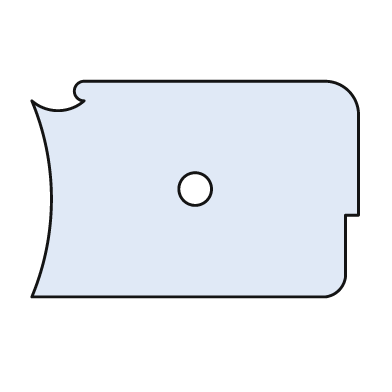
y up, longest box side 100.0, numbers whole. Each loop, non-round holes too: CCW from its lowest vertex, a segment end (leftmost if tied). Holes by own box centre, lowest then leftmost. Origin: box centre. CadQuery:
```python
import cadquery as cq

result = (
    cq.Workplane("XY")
    .moveTo(-50.0, -33.0)
    .lineTo(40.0, -33.0)
    .threePointArc((44.0, -31.0), (46.0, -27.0))
    .lineTo(46.0, -8.0)
    .lineTo(50.0, -8.0)
    .lineTo(50.0, 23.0)
    .threePointArc((47.0, 30.0), (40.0, 33.0))
    .lineTo(-34.0, 33.0)
    .threePointArc((-37.0, 30.0), (-34.0, 27.0))
    .threePointArc((-42.0, 24.0), (-50.0, 27.0))
    .threePointArc((-44.0, -3.0), (-50.0, -33.0))
    .close()
    .moveTo(0.0, 0.0)
    .circle(5.0)
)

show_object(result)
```